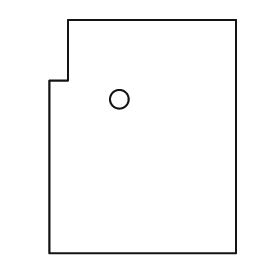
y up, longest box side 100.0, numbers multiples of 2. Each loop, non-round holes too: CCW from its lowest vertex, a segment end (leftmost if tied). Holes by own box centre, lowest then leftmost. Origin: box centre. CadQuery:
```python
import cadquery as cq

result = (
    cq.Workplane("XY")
    .moveTo(-40.0, -50.0)
    .lineTo(40.0, -50.0)
    .lineTo(40.0, 50.0)
    .lineTo(-32.0, 50.0)
    .lineTo(-32.0, 24.0)
    .lineTo(-40.0, 24.0)
    .close()
    .moveTo(-10.0, 16.0)
    .circle(4.0)
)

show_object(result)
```